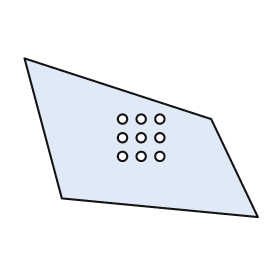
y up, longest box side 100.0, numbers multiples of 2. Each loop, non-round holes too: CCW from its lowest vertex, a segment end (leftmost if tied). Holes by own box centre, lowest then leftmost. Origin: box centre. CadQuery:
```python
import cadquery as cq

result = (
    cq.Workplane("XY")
    .moveTo(50.0, -34.0)
    .lineTo(30.0, 8.0)
    .lineTo(-50.0, 34.0)
    .lineTo(-34.0, -26.0)
    .close()
    .moveTo(-8.0, -8.0)
    .circle(2.0)
    .moveTo(0.0, -8.0)
    .circle(2.0)
    .moveTo(8.0, -8.0)
    .circle(2.0)
    .moveTo(-8.0, 0.0)
    .circle(2.0)
    .moveTo(0.0, 0.0)
    .circle(2.0)
    .moveTo(8.0, 0.0)
    .circle(2.0)
    .moveTo(-8.0, 8.0)
    .circle(2.0)
    .moveTo(0.0, 8.0)
    .circle(2.0)
    .moveTo(8.0, 8.0)
    .circle(2.0)
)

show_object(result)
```